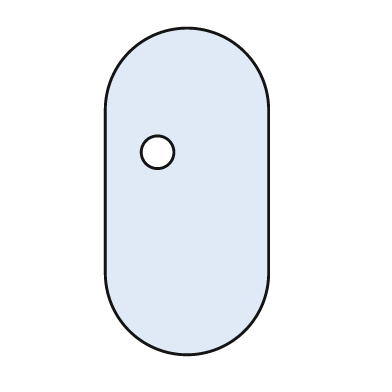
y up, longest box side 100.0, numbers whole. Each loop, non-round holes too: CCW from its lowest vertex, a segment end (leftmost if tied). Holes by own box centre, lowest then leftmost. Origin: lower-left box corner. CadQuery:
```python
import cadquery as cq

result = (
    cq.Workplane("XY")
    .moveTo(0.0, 25.0)
    .threePointArc((25.0, 0.0), (50.0, 25.0))
    .lineTo(50.0, 75.0)
    .threePointArc((25.0, 100.0), (0.0, 75.0))
    .close()
    .moveTo(16.0, 62.0)
    .circle(5.0)
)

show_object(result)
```